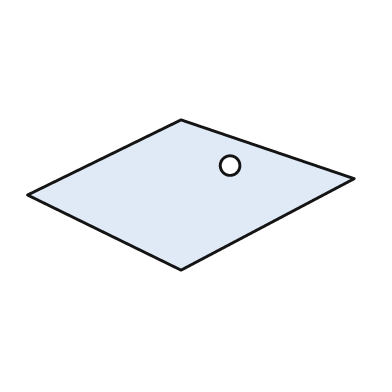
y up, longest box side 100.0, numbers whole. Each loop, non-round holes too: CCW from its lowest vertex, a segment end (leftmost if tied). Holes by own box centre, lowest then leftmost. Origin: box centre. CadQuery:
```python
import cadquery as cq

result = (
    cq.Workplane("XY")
    .moveTo(-3.0, -23.0)
    .lineTo(50.0, 5.0)
    .lineTo(-3.0, 23.0)
    .lineTo(-50.0, 0.0)
    .close()
    .moveTo(12.0, 9.0)
    .circle(3.0)
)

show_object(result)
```